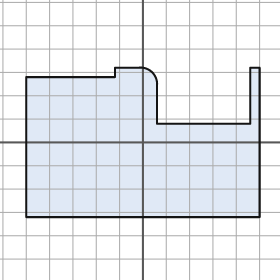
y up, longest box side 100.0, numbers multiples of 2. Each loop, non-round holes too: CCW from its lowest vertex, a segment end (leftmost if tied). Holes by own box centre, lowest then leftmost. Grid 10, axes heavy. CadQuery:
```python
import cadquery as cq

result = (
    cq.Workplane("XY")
    .moveTo(-50.0, -32.0)
    .lineTo(50.0, -32.0)
    .lineTo(50.0, 32.0)
    .lineTo(46.0, 32.0)
    .lineTo(46.0, 8.0)
    .lineTo(6.0, 8.0)
    .lineTo(6.0, 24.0)
    .threePointArc((4.0, 30.0), (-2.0, 32.0))
    .lineTo(-12.0, 32.0)
    .lineTo(-12.0, 28.0)
    .lineTo(-50.0, 28.0)
    .close()
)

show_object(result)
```